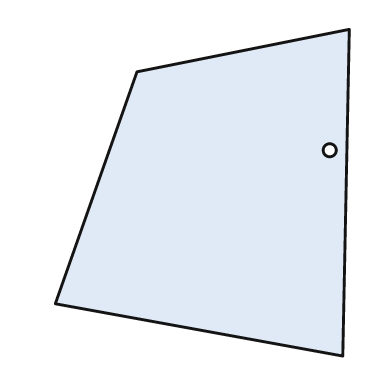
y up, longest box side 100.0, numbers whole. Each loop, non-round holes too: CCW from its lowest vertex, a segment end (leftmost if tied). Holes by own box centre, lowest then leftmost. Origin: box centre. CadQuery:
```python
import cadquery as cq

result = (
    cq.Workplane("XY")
    .moveTo(43.0, -50.0)
    .lineTo(45.0, 50.0)
    .lineTo(-20.0, 37.0)
    .lineTo(-45.0, -34.0)
    .close()
    .moveTo(39.0, 13.0)
    .circle(2.0)
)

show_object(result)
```